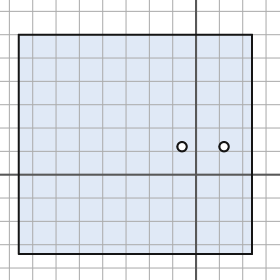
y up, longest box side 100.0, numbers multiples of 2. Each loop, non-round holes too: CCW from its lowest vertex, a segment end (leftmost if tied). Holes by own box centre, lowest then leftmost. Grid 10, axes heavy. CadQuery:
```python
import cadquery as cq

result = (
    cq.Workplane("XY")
    .moveTo(-76.0, -34.0)
    .lineTo(24.0, -34.0)
    .lineTo(24.0, 60.0)
    .lineTo(-76.0, 60.0)
    .close()
    .moveTo(-6.0, 12.0)
    .circle(2.0)
    .moveTo(12.0, 12.0)
    .circle(2.0)
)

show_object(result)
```